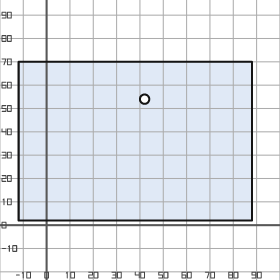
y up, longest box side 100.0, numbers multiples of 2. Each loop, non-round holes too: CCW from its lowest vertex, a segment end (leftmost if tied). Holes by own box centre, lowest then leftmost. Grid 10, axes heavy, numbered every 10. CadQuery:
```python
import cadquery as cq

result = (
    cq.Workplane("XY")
    .moveTo(-12.0, 2.0)
    .lineTo(88.0, 2.0)
    .lineTo(88.0, 70.0)
    .lineTo(-12.0, 70.0)
    .close()
    .moveTo(42.0, 54.0)
    .circle(2.0)
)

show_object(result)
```